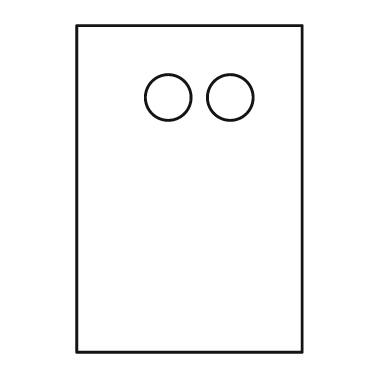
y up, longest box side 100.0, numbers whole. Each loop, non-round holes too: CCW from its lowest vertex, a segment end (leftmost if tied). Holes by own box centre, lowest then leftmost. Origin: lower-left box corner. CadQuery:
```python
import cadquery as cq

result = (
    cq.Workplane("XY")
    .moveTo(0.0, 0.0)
    .lineTo(69.0, 0.0)
    .lineTo(69.0, 100.0)
    .lineTo(0.0, 100.0)
    .close()
    .moveTo(28.0, 78.0)
    .circle(7.0)
    .moveTo(47.0, 78.0)
    .circle(7.0)
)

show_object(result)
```